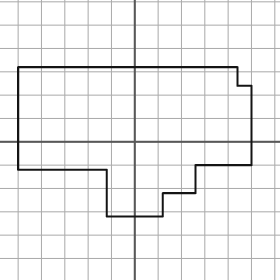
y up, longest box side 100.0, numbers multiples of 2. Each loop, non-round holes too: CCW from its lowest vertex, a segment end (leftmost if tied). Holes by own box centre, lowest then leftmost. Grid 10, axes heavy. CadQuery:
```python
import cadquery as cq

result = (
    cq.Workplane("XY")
    .moveTo(-12.0, -32.0)
    .lineTo(12.0, -32.0)
    .lineTo(12.0, -22.0)
    .lineTo(26.0, -22.0)
    .lineTo(26.0, -10.0)
    .lineTo(50.0, -10.0)
    .lineTo(50.0, 24.0)
    .lineTo(44.0, 24.0)
    .lineTo(44.0, 32.0)
    .lineTo(-50.0, 32.0)
    .lineTo(-50.0, -12.0)
    .lineTo(-12.0, -12.0)
    .close()
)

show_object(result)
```